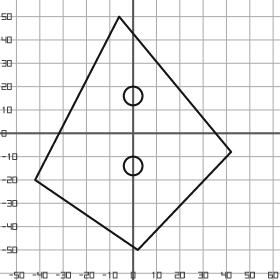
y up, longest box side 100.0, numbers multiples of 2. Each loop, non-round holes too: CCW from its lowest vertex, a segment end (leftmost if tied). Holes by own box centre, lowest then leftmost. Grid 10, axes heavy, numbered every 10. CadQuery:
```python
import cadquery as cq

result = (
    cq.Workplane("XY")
    .moveTo(2.0, -50.0)
    .lineTo(42.0, -8.0)
    .lineTo(-6.0, 50.0)
    .lineTo(-42.0, -20.0)
    .close()
    .moveTo(0.0, -14.0)
    .circle(4.0)
    .moveTo(0.0, 16.0)
    .circle(4.0)
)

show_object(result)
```